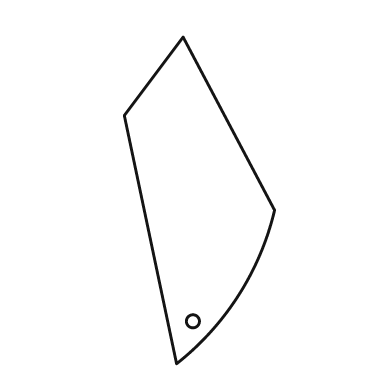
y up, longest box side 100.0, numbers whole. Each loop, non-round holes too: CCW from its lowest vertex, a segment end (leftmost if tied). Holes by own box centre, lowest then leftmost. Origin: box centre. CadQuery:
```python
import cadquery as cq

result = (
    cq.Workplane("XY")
    .moveTo(-7.0, -50.0)
    .threePointArc((12.0, -29.0), (23.0, -3.0))
    .lineTo(-5.0, 50.0)
    .lineTo(-23.0, 26.0)
    .close()
    .moveTo(-2.0, -37.0)
    .circle(2.0)
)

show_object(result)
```